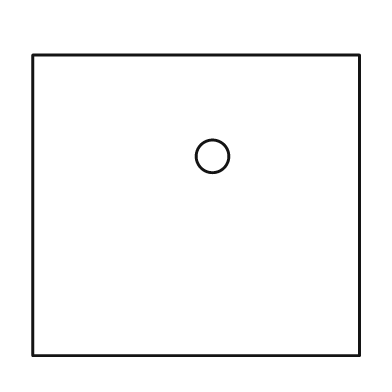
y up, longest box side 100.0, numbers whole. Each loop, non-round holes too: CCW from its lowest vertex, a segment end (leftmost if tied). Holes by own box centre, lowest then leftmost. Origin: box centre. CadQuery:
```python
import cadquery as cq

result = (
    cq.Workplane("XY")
    .moveTo(-50.0, -46.0)
    .lineTo(50.0, -46.0)
    .lineTo(50.0, 46.0)
    .lineTo(-50.0, 46.0)
    .close()
    .moveTo(5.0, 15.0)
    .circle(5.0)
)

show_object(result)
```